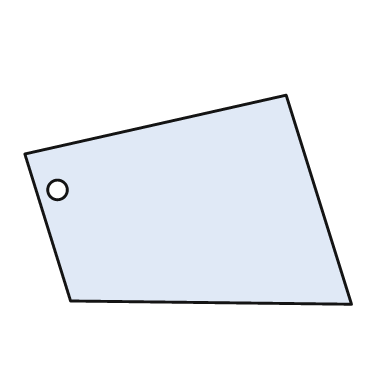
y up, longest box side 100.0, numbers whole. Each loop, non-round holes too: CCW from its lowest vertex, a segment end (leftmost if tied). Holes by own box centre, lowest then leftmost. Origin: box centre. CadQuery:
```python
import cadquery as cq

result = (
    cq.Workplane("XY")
    .moveTo(50.0, -32.0)
    .lineTo(30.0, 32.0)
    .lineTo(-50.0, 14.0)
    .lineTo(-36.0, -31.0)
    .close()
    .moveTo(-40.0, 3.0)
    .circle(3.0)
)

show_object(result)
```